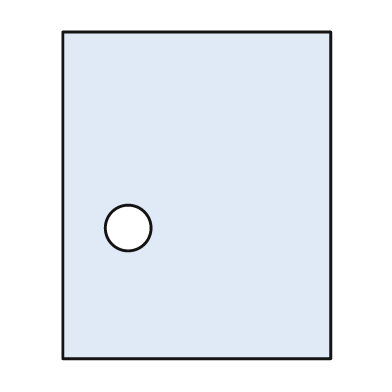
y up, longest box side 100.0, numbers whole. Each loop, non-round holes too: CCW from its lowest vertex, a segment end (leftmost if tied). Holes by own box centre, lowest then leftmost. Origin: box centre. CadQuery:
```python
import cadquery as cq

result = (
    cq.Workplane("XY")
    .moveTo(-41.0, -50.0)
    .lineTo(41.0, -50.0)
    .lineTo(41.0, 50.0)
    .lineTo(-41.0, 50.0)
    .close()
    .moveTo(-21.0, -10.0)
    .circle(7.0)
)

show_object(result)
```